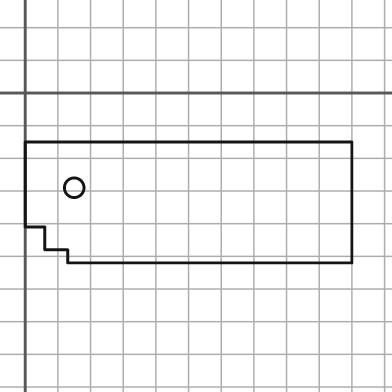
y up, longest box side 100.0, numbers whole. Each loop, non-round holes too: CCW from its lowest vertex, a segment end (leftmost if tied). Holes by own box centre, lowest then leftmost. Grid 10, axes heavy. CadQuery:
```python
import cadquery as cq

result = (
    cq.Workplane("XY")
    .moveTo(13.0, -52.0)
    .lineTo(100.0, -52.0)
    .lineTo(100.0, -15.0)
    .lineTo(0.0, -15.0)
    .lineTo(0.0, -41.0)
    .lineTo(6.0, -41.0)
    .lineTo(6.0, -48.0)
    .lineTo(13.0, -48.0)
    .close()
    .moveTo(15.0, -29.0)
    .circle(3.0)
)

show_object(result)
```